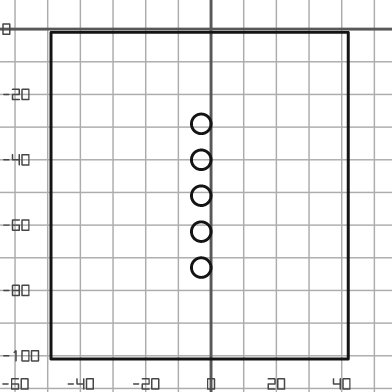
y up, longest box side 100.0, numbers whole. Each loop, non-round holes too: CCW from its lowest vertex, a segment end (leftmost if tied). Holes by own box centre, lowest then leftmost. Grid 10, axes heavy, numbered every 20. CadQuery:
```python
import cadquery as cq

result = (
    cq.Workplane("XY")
    .moveTo(-49.0, -101.0)
    .lineTo(42.0, -101.0)
    .lineTo(42.0, -1.0)
    .lineTo(-49.0, -1.0)
    .close()
    .moveTo(-3.0, -73.0)
    .circle(3.0)
    .moveTo(-3.0, -62.0)
    .circle(3.0)
    .moveTo(-3.0, -51.0)
    .circle(3.0)
    .moveTo(-3.0, -40.0)
    .circle(3.0)
    .moveTo(-3.0, -29.0)
    .circle(3.0)
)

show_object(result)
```